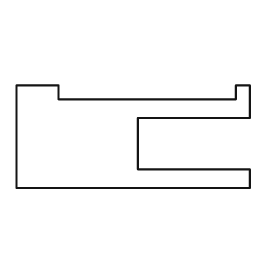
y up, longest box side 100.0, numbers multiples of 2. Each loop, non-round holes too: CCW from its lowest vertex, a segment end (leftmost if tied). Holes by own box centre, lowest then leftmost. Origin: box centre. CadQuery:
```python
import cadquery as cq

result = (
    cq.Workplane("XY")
    .moveTo(-50.0, -22.0)
    .lineTo(50.0, -22.0)
    .lineTo(50.0, -14.0)
    .lineTo(2.0, -14.0)
    .lineTo(2.0, 8.0)
    .lineTo(50.0, 8.0)
    .lineTo(50.0, 22.0)
    .lineTo(44.0, 22.0)
    .lineTo(44.0, 16.0)
    .lineTo(-32.0, 16.0)
    .lineTo(-32.0, 22.0)
    .lineTo(-50.0, 22.0)
    .close()
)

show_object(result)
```